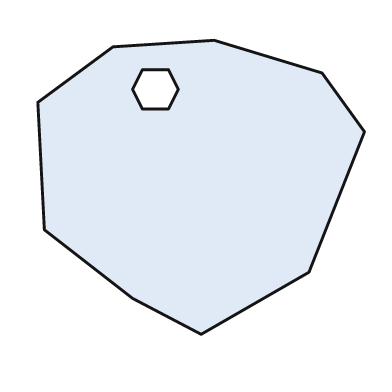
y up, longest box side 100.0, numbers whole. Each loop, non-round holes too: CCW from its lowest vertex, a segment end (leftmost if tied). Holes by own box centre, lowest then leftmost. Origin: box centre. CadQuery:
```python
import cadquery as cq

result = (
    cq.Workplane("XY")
    .moveTo(0.0, -45.0)
    .lineTo(33.0, -26.0)
    .lineTo(50.0, 17.0)
    .lineTo(37.0, 35.0)
    .lineTo(4.0, 45.0)
    .lineTo(-27.0, 43.0)
    .lineTo(-50.0, 26.0)
    .lineTo(-48.0, -13.0)
    .lineTo(-21.0, -34.0)
    .close()
    .moveTo(-18.0, 24.0)
    .lineTo(-10.0, 24.0)
    .lineTo(-7.0, 30.0)
    .lineTo(-10.0, 36.0)
    .lineTo(-18.0, 36.0)
    .lineTo(-21.0, 30.0)
    .close()
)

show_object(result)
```